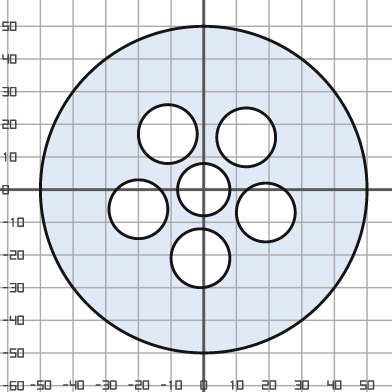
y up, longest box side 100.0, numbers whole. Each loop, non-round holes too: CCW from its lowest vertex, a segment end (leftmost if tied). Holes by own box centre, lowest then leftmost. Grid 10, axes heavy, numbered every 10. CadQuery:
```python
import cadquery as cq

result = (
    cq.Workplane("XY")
    .moveTo(0.0, 0.0)
    .circle(50.0)
    .moveTo(-1.0, -21.0)
    .circle(9.0)
    .moveTo(19.0, -7.0)
    .circle(9.0)
    .moveTo(-20.0, -6.0)
    .circle(9.0)
    .moveTo(0.0, 0.0)
    .circle(8.0)
    .moveTo(13.0, 16.0)
    .circle(9.0)
    .moveTo(-11.0, 17.0)
    .circle(9.0)
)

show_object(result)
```